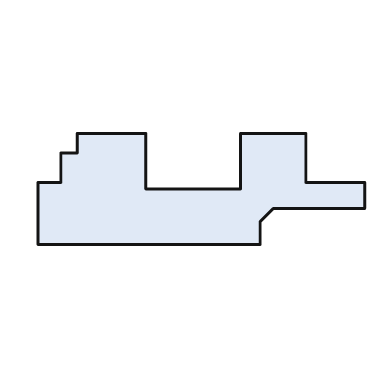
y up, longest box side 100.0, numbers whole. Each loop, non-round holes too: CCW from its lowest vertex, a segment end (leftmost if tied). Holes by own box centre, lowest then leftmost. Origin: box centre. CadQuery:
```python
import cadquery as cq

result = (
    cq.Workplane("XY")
    .moveTo(-50.0, -17.0)
    .lineTo(18.0, -17.0)
    .lineTo(18.0, -10.0)
    .lineTo(22.0, -6.0)
    .lineTo(50.0, -6.0)
    .lineTo(50.0, 2.0)
    .lineTo(32.0, 2.0)
    .lineTo(32.0, 17.0)
    .lineTo(12.0, 17.0)
    .lineTo(12.0, 0.0)
    .lineTo(-17.0, 0.0)
    .lineTo(-17.0, 17.0)
    .lineTo(-38.0, 17.0)
    .lineTo(-38.0, 11.0)
    .lineTo(-43.0, 11.0)
    .lineTo(-43.0, 2.0)
    .lineTo(-50.0, 2.0)
    .close()
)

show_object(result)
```